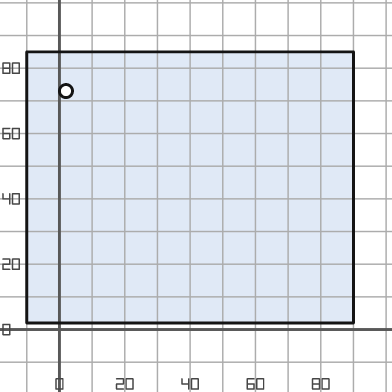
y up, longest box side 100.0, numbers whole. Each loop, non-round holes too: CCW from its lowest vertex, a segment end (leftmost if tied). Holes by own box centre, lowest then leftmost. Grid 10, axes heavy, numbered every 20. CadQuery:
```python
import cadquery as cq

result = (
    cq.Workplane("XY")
    .moveTo(-10.0, 2.0)
    .lineTo(90.0, 2.0)
    .lineTo(90.0, 85.0)
    .lineTo(-10.0, 85.0)
    .close()
    .moveTo(2.0, 73.0)
    .circle(2.0)
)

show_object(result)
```